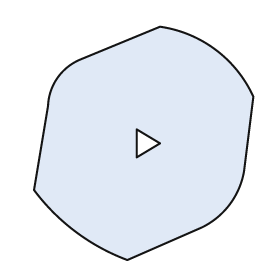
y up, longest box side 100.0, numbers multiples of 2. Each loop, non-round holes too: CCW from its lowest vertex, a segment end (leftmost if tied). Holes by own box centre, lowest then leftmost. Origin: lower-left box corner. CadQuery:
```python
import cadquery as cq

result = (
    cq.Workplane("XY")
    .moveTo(40.0, 0.0)
    .lineTo(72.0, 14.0)
    .threePointArc((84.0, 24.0), (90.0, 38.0))
    .lineTo(94.0, 70.0)
    .threePointArc((78.0, 90.0), (54.0, 100.0))
    .lineTo(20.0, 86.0)
    .threePointArc((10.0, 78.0), (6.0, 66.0))
    .lineTo(0.0, 30.0)
    .threePointArc((18.0, 12.0), (40.0, 0.0))
    .close()
    .moveTo(44.0, 44.0)
    .lineTo(54.0, 50.0)
    .lineTo(44.0, 56.0)
    .close()
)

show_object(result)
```